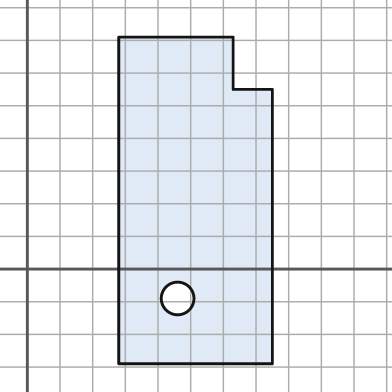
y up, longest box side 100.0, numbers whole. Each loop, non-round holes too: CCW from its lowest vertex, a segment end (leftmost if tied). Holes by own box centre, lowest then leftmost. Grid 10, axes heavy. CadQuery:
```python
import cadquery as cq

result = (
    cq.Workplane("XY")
    .moveTo(28.0, -29.0)
    .lineTo(75.0, -29.0)
    .lineTo(75.0, 55.0)
    .lineTo(63.0, 55.0)
    .lineTo(63.0, 71.0)
    .lineTo(28.0, 71.0)
    .close()
    .moveTo(46.0, -9.0)
    .circle(5.0)
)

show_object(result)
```